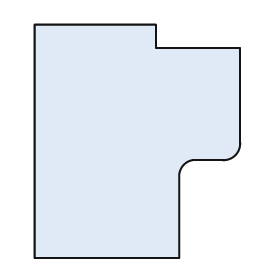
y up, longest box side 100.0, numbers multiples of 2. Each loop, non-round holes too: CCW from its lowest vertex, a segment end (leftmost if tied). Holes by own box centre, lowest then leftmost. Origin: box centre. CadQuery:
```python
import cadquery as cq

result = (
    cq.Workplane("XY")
    .moveTo(-44.0, -50.0)
    .lineTo(18.0, -50.0)
    .lineTo(18.0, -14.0)
    .threePointArc((20.0, -10.0), (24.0, -8.0))
    .lineTo(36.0, -8.0)
    .threePointArc((42.0, -6.0), (44.0, 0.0))
    .lineTo(44.0, 40.0)
    .lineTo(8.0, 40.0)
    .lineTo(8.0, 50.0)
    .lineTo(-44.0, 50.0)
    .close()
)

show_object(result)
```